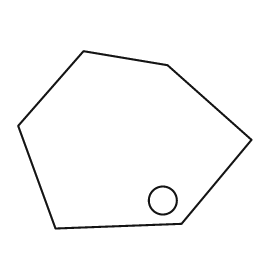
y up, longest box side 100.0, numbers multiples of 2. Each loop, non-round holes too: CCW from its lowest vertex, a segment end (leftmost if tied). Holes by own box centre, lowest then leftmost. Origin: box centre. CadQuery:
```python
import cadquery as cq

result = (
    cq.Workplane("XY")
    .moveTo(-34.0, -38.0)
    .lineTo(20.0, -36.0)
    .lineTo(50.0, 0.0)
    .lineTo(14.0, 32.0)
    .lineTo(-22.0, 38.0)
    .lineTo(-50.0, 6.0)
    .close()
    .moveTo(12.0, -26.0)
    .circle(6.0)
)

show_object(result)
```